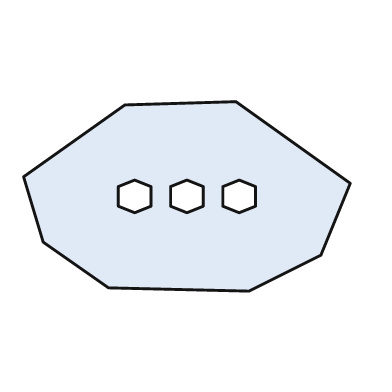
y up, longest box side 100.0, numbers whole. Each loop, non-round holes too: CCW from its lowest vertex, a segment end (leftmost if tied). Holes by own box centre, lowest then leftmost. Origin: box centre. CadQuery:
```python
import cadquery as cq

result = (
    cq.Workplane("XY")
    .moveTo(19.0, -29.0)
    .lineTo(41.0, -18.0)
    .lineTo(50.0, 4.0)
    .lineTo(15.0, 29.0)
    .lineTo(-19.0, 28.0)
    .lineTo(-50.0, 6.0)
    .lineTo(-44.0, -14.0)
    .lineTo(-24.0, -28.0)
    .close()
    .moveTo(-16.0, -5.0)
    .lineTo(-11.0, -3.0)
    .lineTo(-11.0, 3.0)
    .lineTo(-16.0, 5.0)
    .lineTo(-21.0, 3.0)
    .lineTo(-21.0, -3.0)
    .close()
    .moveTo(0.0, -5.0)
    .lineTo(5.0, -3.0)
    .lineTo(5.0, 3.0)
    .lineTo(0.0, 5.0)
    .lineTo(-5.0, 3.0)
    .lineTo(-5.0, -3.0)
    .close()
    .moveTo(16.0, -5.0)
    .lineTo(21.0, -3.0)
    .lineTo(21.0, 3.0)
    .lineTo(16.0, 5.0)
    .lineTo(11.0, 3.0)
    .lineTo(11.0, -3.0)
    .close()
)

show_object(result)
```